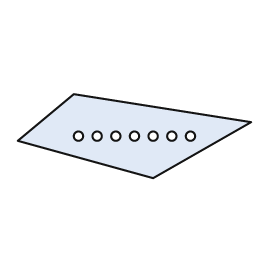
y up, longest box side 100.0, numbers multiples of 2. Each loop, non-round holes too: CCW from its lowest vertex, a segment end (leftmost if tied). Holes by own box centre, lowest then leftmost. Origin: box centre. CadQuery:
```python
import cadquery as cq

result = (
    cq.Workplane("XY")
    .moveTo(8.0, -18.0)
    .lineTo(50.0, 6.0)
    .lineTo(-26.0, 18.0)
    .lineTo(-50.0, -2.0)
    .close()
    .moveTo(-24.0, 0.0)
    .circle(2.0)
    .moveTo(-16.0, 0.0)
    .circle(2.0)
    .moveTo(-8.0, 0.0)
    .circle(2.0)
    .moveTo(0.0, 0.0)
    .circle(2.0)
    .moveTo(8.0, 0.0)
    .circle(2.0)
    .moveTo(16.0, 0.0)
    .circle(2.0)
    .moveTo(24.0, 0.0)
    .circle(2.0)
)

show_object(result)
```